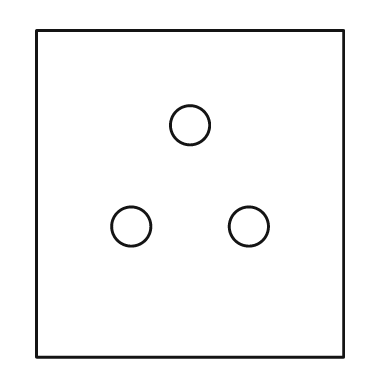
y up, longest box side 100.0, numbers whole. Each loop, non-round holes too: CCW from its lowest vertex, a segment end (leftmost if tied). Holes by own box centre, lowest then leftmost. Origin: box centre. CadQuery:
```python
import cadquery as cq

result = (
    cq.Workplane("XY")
    .moveTo(-47.0, -50.0)
    .lineTo(47.0, -50.0)
    .lineTo(47.0, 50.0)
    .lineTo(-47.0, 50.0)
    .close()
    .moveTo(-18.0, -10.0)
    .circle(6.0)
    .moveTo(18.0, -10.0)
    .circle(6.0)
    .moveTo(0.0, 21.0)
    .circle(6.0)
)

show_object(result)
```